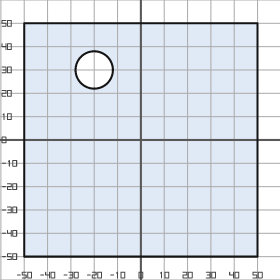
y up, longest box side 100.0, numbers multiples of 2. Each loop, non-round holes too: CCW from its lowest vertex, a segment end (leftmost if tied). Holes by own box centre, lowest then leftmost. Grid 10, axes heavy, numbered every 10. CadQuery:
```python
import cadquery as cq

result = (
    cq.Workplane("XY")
    .moveTo(-50.0, -50.0)
    .lineTo(50.0, -50.0)
    .lineTo(50.0, 50.0)
    .lineTo(-50.0, 50.0)
    .close()
    .moveTo(-20.0, 30.0)
    .circle(8.0)
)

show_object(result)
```